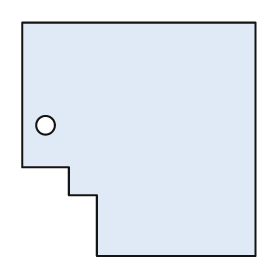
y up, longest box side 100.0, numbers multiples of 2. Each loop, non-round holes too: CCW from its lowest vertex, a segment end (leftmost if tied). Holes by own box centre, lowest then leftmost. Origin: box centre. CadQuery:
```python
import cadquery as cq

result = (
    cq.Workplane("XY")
    .moveTo(-18.0, -50.0)
    .lineTo(50.0, -50.0)
    .lineTo(50.0, 50.0)
    .lineTo(-50.0, 50.0)
    .lineTo(-50.0, -12.0)
    .lineTo(-30.0, -12.0)
    .lineTo(-30.0, -24.0)
    .lineTo(-18.0, -24.0)
    .close()
    .moveTo(-40.0, 6.0)
    .circle(4.0)
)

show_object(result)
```